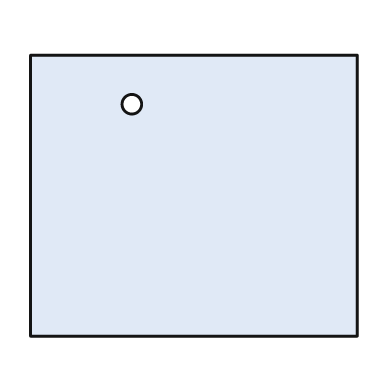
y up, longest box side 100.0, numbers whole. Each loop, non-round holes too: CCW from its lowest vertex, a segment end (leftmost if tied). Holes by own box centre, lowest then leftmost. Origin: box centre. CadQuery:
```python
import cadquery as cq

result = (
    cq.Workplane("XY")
    .moveTo(-50.0, -43.0)
    .lineTo(50.0, -43.0)
    .lineTo(50.0, 43.0)
    .lineTo(-50.0, 43.0)
    .close()
    .moveTo(-19.0, 28.0)
    .circle(3.0)
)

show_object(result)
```